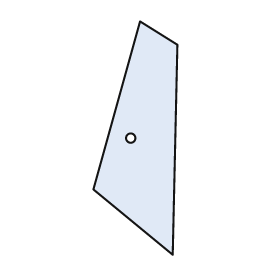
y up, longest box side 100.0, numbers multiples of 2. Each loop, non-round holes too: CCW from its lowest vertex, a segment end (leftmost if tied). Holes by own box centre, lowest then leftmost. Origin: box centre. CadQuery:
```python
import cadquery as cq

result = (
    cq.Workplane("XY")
    .moveTo(16.0, -50.0)
    .lineTo(18.0, 40.0)
    .lineTo(2.0, 50.0)
    .lineTo(-18.0, -22.0)
    .close()
    .moveTo(-2.0, 0.0)
    .circle(2.0)
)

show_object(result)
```